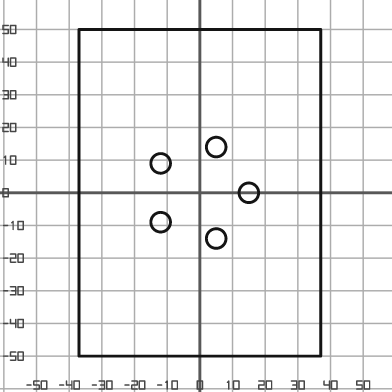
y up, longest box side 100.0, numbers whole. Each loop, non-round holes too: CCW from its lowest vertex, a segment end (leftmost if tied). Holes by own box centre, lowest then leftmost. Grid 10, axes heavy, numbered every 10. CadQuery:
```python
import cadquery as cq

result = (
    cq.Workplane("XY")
    .moveTo(-37.0, -50.0)
    .lineTo(37.0, -50.0)
    .lineTo(37.0, 50.0)
    .lineTo(-37.0, 50.0)
    .close()
    .moveTo(5.0, -14.0)
    .circle(3.0)
    .moveTo(-12.0, -9.0)
    .circle(3.0)
    .moveTo(15.0, 0.0)
    .circle(3.0)
    .moveTo(-12.0, 9.0)
    .circle(3.0)
    .moveTo(5.0, 14.0)
    .circle(3.0)
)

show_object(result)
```